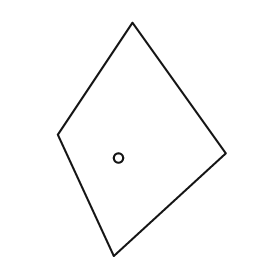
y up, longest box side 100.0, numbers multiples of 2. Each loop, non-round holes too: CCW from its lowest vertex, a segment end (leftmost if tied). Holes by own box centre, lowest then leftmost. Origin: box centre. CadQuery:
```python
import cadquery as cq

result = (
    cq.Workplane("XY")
    .moveTo(-12.0, -50.0)
    .lineTo(36.0, -6.0)
    .lineTo(-4.0, 50.0)
    .lineTo(-36.0, 2.0)
    .close()
    .moveTo(-10.0, -8.0)
    .circle(2.0)
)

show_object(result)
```